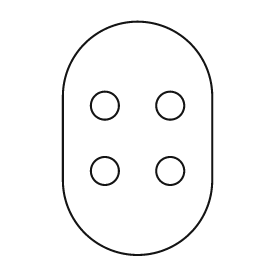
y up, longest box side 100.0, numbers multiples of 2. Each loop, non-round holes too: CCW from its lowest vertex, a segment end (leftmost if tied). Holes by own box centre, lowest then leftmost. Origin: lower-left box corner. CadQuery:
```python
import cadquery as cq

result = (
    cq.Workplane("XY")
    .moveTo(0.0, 32.0)
    .threePointArc((32.0, 0.0), (64.0, 32.0))
    .lineTo(64.0, 68.0)
    .threePointArc((32.0, 100.0), (0.0, 68.0))
    .close()
    .moveTo(18.0, 36.0)
    .circle(6.0)
    .moveTo(46.0, 36.0)
    .circle(6.0)
    .moveTo(18.0, 64.0)
    .circle(6.0)
    .moveTo(46.0, 64.0)
    .circle(6.0)
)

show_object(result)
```